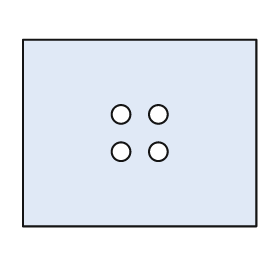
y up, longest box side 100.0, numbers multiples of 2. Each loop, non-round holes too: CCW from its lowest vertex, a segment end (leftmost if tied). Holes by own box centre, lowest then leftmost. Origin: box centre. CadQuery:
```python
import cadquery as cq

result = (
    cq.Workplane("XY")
    .moveTo(-50.0, -40.0)
    .lineTo(50.0, -40.0)
    .lineTo(50.0, 40.0)
    .lineTo(-50.0, 40.0)
    .close()
    .moveTo(-8.0, -8.0)
    .circle(4.0)
    .moveTo(8.0, -8.0)
    .circle(4.0)
    .moveTo(-8.0, 8.0)
    .circle(4.0)
    .moveTo(8.0, 8.0)
    .circle(4.0)
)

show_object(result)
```